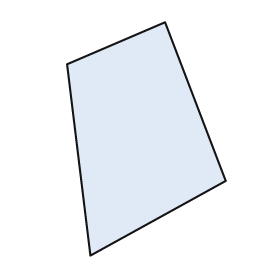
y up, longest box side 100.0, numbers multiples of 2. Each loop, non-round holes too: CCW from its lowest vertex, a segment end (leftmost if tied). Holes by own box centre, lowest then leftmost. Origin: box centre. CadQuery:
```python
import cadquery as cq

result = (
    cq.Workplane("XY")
    .moveTo(-24.0, -50.0)
    .lineTo(34.0, -18.0)
    .lineTo(8.0, 50.0)
    .lineTo(-34.0, 32.0)
    .close()
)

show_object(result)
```